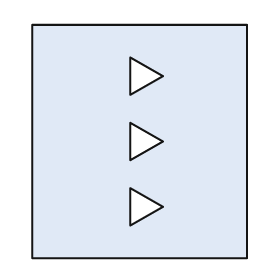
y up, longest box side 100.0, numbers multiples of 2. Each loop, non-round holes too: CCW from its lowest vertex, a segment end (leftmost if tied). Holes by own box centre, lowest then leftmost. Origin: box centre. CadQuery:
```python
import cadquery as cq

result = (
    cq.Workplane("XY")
    .moveTo(-46.0, -50.0)
    .lineTo(46.0, -50.0)
    .lineTo(46.0, 50.0)
    .lineTo(-46.0, 50.0)
    .close()
    .moveTo(-4.0, -36.0)
    .lineTo(10.0, -28.0)
    .lineTo(-4.0, -20.0)
    .close()
    .moveTo(-4.0, -8.0)
    .lineTo(10.0, 0.0)
    .lineTo(-4.0, 8.0)
    .close()
    .moveTo(-4.0, 20.0)
    .lineTo(10.0, 28.0)
    .lineTo(-4.0, 36.0)
    .close()
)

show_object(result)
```